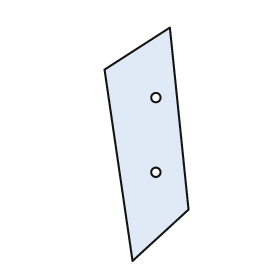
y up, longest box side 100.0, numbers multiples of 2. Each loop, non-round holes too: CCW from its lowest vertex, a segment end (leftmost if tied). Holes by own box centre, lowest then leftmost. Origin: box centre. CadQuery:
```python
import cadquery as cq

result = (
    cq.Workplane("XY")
    .moveTo(-6.0, -50.0)
    .lineTo(18.0, -28.0)
    .lineTo(10.0, 50.0)
    .lineTo(-18.0, 32.0)
    .close()
    .moveTo(4.0, -12.0)
    .circle(2.0)
    .moveTo(4.0, 20.0)
    .circle(2.0)
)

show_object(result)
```